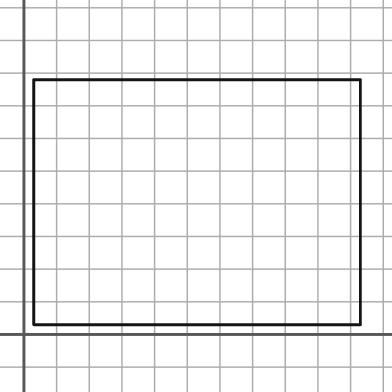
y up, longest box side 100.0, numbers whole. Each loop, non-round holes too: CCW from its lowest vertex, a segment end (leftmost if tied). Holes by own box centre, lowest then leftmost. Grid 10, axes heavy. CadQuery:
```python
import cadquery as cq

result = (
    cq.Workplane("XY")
    .moveTo(3.0, 3.0)
    .lineTo(103.0, 3.0)
    .lineTo(103.0, 78.0)
    .lineTo(3.0, 78.0)
    .close()
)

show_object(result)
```